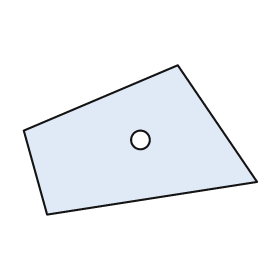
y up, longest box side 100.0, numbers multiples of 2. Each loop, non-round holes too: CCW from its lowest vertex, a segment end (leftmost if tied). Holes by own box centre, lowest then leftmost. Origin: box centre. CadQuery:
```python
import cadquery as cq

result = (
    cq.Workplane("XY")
    .moveTo(-40.0, -32.0)
    .lineTo(50.0, -18.0)
    .lineTo(16.0, 32.0)
    .lineTo(-50.0, 4.0)
    .close()
    .moveTo(0.0, 0.0)
    .circle(4.0)
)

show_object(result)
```